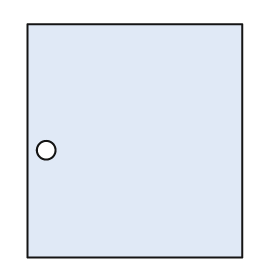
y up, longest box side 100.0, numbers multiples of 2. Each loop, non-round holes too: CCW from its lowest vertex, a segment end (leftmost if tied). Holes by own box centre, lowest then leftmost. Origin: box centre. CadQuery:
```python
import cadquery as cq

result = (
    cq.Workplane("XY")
    .moveTo(-46.0, -50.0)
    .lineTo(46.0, -50.0)
    .lineTo(46.0, 50.0)
    .lineTo(-46.0, 50.0)
    .close()
    .moveTo(-38.0, -4.0)
    .circle(4.0)
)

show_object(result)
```